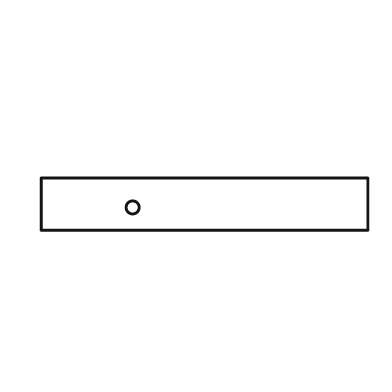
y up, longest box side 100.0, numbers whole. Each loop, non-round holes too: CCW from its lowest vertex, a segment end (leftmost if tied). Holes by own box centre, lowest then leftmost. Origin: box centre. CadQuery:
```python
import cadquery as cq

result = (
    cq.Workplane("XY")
    .moveTo(-50.0, -8.0)
    .lineTo(50.0, -8.0)
    .lineTo(50.0, 8.0)
    .lineTo(-50.0, 8.0)
    .close()
    .moveTo(-22.0, -1.0)
    .circle(2.0)
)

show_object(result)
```